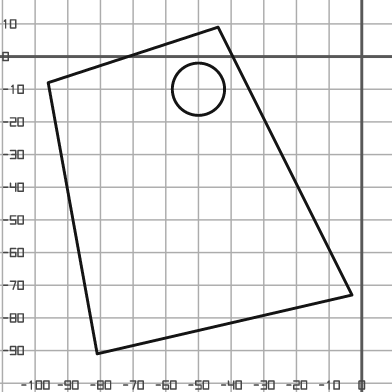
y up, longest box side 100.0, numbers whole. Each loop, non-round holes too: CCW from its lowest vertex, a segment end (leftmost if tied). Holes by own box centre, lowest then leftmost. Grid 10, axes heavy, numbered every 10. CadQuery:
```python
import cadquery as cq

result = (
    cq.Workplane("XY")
    .moveTo(-81.0, -91.0)
    .lineTo(-3.0, -73.0)
    .lineTo(-44.0, 9.0)
    .lineTo(-96.0, -8.0)
    .close()
    .moveTo(-50.0, -10.0)
    .circle(8.0)
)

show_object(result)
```